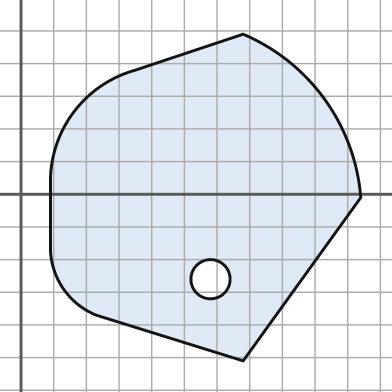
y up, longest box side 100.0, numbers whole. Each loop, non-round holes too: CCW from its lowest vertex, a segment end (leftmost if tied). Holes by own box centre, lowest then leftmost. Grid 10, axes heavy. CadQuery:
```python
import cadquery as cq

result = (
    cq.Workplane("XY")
    .moveTo(68.0, -51.0)
    .lineTo(104.0, -1.0)
    .threePointArc((93.0, 29.0), (68.0, 49.0))
    .lineTo(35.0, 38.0)
    .threePointArc((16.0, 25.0), (9.0, 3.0))
    .lineTo(9.0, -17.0)
    .threePointArc((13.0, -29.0), (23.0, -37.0))
    .close()
    .moveTo(58.0, -26.0)
    .circle(6.0)
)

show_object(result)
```